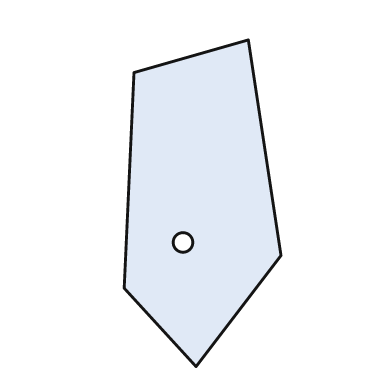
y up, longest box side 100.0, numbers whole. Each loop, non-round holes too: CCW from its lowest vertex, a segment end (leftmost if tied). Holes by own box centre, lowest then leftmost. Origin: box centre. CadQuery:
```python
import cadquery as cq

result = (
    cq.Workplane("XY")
    .moveTo(-2.0, -50.0)
    .lineTo(24.0, -16.0)
    .lineTo(14.0, 50.0)
    .lineTo(-21.0, 40.0)
    .lineTo(-24.0, -26.0)
    .close()
    .moveTo(-6.0, -12.0)
    .circle(3.0)
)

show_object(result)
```